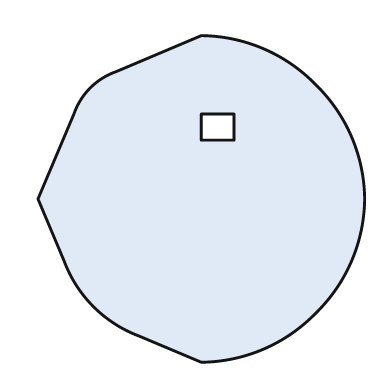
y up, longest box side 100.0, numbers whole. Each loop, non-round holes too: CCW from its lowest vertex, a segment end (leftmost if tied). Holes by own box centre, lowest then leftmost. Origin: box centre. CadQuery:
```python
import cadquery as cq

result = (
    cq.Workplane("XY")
    .moveTo(0.0, -50.0)
    .threePointArc((19.0, -46.0), (35.0, -35.0))
    .threePointArc((46.0, -19.0), (50.0, 0.0))
    .threePointArc((46.0, 19.0), (35.0, 35.0))
    .threePointArc((19.0, 46.0), (0.0, 50.0))
    .lineTo(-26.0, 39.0)
    .threePointArc((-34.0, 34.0), (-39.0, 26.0))
    .lineTo(-50.0, 0.0)
    .lineTo(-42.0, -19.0)
    .threePointArc((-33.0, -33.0), (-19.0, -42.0))
    .close()
    .moveTo(0.0, 18.0)
    .lineTo(10.0, 18.0)
    .lineTo(10.0, 26.0)
    .lineTo(0.0, 26.0)
    .close()
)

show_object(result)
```